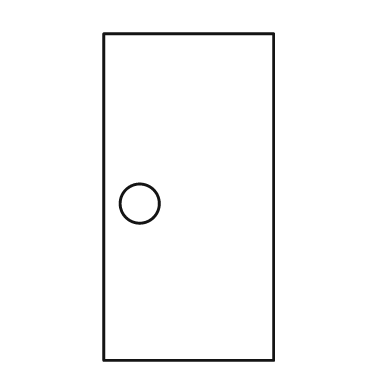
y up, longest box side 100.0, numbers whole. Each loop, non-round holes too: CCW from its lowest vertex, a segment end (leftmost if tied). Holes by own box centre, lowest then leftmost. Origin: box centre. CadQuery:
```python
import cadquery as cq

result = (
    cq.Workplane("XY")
    .moveTo(-26.0, -50.0)
    .lineTo(26.0, -50.0)
    .lineTo(26.0, 50.0)
    .lineTo(-26.0, 50.0)
    .close()
    .moveTo(-15.0, -2.0)
    .circle(6.0)
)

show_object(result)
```